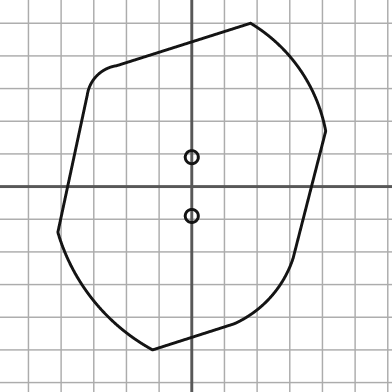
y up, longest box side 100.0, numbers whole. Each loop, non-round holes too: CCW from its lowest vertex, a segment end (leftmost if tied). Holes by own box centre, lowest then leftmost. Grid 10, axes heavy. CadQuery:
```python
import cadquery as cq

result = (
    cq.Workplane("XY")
    .moveTo(-12.0, -50.0)
    .lineTo(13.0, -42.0)
    .threePointArc((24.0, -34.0), (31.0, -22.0))
    .lineTo(41.0, 17.0)
    .threePointArc((33.0, 36.0), (18.0, 50.0))
    .lineTo(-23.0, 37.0)
    .threePointArc((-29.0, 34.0), (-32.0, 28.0))
    .lineTo(-41.0, -14.0)
    .threePointArc((-30.0, -35.0), (-12.0, -50.0))
    .close()
    .moveTo(0.0, -9.0)
    .circle(2.0)
    .moveTo(0.0, 9.0)
    .circle(2.0)
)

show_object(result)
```